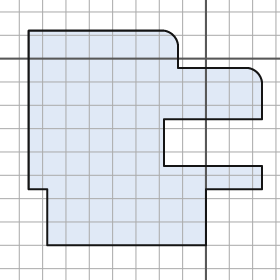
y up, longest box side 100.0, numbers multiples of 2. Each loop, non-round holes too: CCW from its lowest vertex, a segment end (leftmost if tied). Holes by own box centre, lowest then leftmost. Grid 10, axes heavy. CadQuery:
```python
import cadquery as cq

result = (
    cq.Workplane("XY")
    .moveTo(-68.0, -80.0)
    .lineTo(0.0, -80.0)
    .lineTo(0.0, -56.0)
    .lineTo(24.0, -56.0)
    .lineTo(24.0, -46.0)
    .lineTo(-18.0, -46.0)
    .lineTo(-18.0, -26.0)
    .lineTo(24.0, -26.0)
    .lineTo(24.0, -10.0)
    .threePointArc((22.0, -6.0), (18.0, -4.0))
    .lineTo(-12.0, -4.0)
    .lineTo(-12.0, 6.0)
    .threePointArc((-14.0, 10.0), (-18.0, 12.0))
    .lineTo(-76.0, 12.0)
    .lineTo(-76.0, -56.0)
    .lineTo(-68.0, -56.0)
    .close()
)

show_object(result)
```